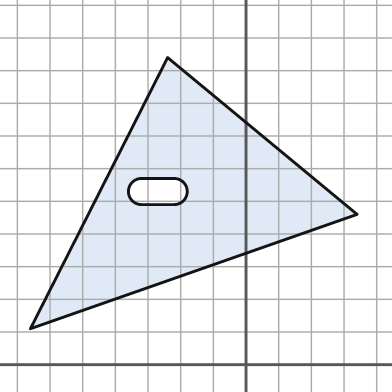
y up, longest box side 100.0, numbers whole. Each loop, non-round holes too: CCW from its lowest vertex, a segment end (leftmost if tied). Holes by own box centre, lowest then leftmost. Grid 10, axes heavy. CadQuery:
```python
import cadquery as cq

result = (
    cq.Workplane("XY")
    .moveTo(-66.0, 11.0)
    .lineTo(34.0, 46.0)
    .lineTo(-24.0, 94.0)
    .close()
    .moveTo(-32.0, 49.0)
    .lineTo(-22.0, 49.0)
    .threePointArc((-18.0, 53.0), (-22.0, 57.0))
    .lineTo(-32.0, 57.0)
    .threePointArc((-36.0, 53.0), (-32.0, 49.0))
    .close()
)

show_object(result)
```